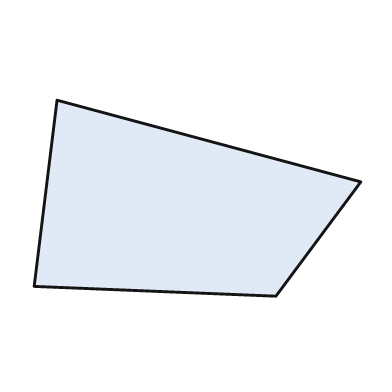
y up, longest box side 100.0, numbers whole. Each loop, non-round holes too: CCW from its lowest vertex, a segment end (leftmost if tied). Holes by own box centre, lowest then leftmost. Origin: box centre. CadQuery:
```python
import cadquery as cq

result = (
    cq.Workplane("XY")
    .moveTo(24.0, -30.0)
    .lineTo(50.0, 5.0)
    .lineTo(-43.0, 30.0)
    .lineTo(-50.0, -27.0)
    .close()
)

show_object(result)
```